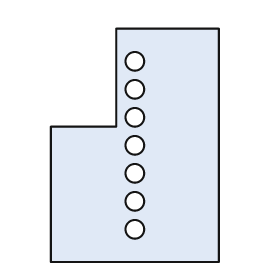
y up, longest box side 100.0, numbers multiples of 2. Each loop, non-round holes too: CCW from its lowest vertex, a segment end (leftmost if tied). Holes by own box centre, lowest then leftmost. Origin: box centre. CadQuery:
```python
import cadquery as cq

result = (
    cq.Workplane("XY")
    .moveTo(-36.0, -50.0)
    .lineTo(36.0, -50.0)
    .lineTo(36.0, 50.0)
    .lineTo(-8.0, 50.0)
    .lineTo(-8.0, 8.0)
    .lineTo(-36.0, 8.0)
    .close()
    .moveTo(0.0, -36.0)
    .circle(4.0)
    .moveTo(0.0, -24.0)
    .circle(4.0)
    .moveTo(0.0, -12.0)
    .circle(4.0)
    .moveTo(0.0, 0.0)
    .circle(4.0)
    .moveTo(0.0, 12.0)
    .circle(4.0)
    .moveTo(0.0, 24.0)
    .circle(4.0)
    .moveTo(0.0, 36.0)
    .circle(4.0)
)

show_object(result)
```